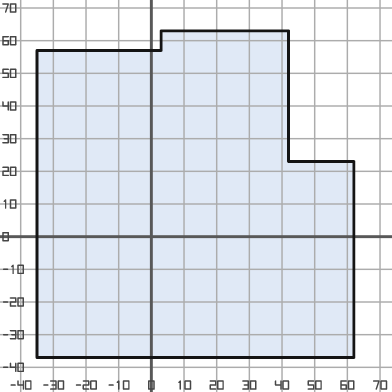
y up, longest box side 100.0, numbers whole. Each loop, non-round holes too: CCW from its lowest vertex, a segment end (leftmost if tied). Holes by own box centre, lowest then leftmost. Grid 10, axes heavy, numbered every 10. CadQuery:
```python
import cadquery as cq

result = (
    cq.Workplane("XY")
    .moveTo(-35.0, -37.0)
    .lineTo(62.0, -37.0)
    .lineTo(62.0, 23.0)
    .lineTo(42.0, 23.0)
    .lineTo(42.0, 63.0)
    .lineTo(3.0, 63.0)
    .lineTo(3.0, 57.0)
    .lineTo(-35.0, 57.0)
    .close()
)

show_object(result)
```